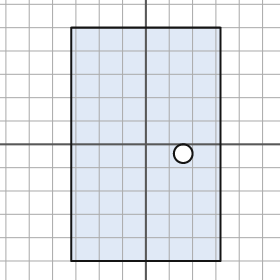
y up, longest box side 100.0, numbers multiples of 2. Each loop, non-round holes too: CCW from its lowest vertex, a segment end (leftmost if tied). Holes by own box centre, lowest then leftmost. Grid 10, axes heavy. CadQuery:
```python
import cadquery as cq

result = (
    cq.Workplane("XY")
    .moveTo(-32.0, -50.0)
    .lineTo(32.0, -50.0)
    .lineTo(32.0, 50.0)
    .lineTo(-32.0, 50.0)
    .close()
    .moveTo(16.0, -4.0)
    .circle(4.0)
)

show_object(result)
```